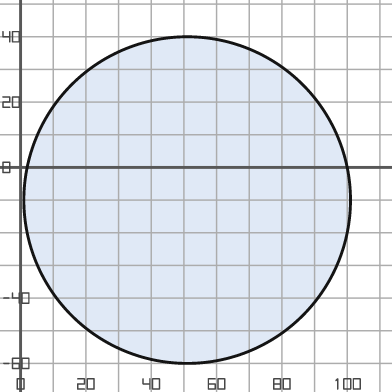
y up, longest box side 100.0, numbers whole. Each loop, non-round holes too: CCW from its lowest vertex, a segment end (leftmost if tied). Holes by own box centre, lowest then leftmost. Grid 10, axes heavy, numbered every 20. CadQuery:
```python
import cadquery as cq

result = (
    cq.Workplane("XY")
    .moveTo(51.0, -10.0)
    .circle(50.0)
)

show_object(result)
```